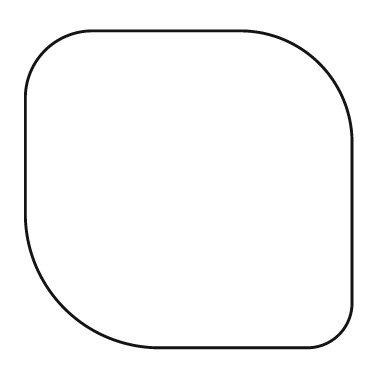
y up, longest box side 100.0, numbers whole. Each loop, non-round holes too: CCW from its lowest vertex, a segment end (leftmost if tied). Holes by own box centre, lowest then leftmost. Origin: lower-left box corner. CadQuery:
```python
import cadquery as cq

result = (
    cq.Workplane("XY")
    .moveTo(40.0, 0.0)
    .lineTo(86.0, 0.0)
    .threePointArc((96.0, 4.0), (100.0, 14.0))
    .lineTo(100.0, 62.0)
    .threePointArc((90.0, 87.0), (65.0, 97.0))
    .lineTo(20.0, 97.0)
    .threePointArc((6.0, 91.0), (0.0, 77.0))
    .lineTo(0.0, 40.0)
    .threePointArc((12.0, 12.0), (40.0, 0.0))
    .close()
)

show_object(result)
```